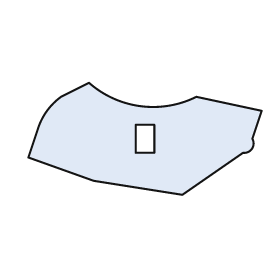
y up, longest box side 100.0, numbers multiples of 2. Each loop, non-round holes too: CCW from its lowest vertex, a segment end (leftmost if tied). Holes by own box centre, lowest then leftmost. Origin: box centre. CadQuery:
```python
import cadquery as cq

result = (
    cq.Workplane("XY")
    .moveTo(16.0, -24.0)
    .lineTo(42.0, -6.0)
    .threePointArc((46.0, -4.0), (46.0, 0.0))
    .lineTo(50.0, 12.0)
    .lineTo(22.0, 18.0)
    .threePointArc((-2.0, 14.0), (-24.0, 24.0))
    .lineTo(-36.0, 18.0)
    .threePointArc((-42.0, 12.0), (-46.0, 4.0))
    .lineTo(-50.0, -8.0)
    .lineTo(-22.0, -18.0)
    .close()
    .moveTo(-4.0, -6.0)
    .lineTo(4.0, -6.0)
    .lineTo(4.0, 6.0)
    .lineTo(-4.0, 6.0)
    .close()
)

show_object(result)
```